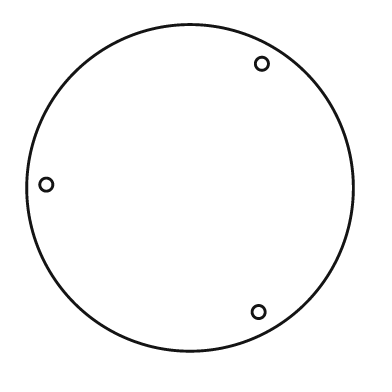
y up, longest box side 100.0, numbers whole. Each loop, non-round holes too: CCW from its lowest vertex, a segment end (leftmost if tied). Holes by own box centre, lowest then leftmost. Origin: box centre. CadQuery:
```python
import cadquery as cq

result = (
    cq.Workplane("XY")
    .moveTo(0.0, 0.0)
    .circle(50.0)
    .moveTo(21.0, -38.0)
    .circle(2.0)
    .moveTo(-44.0, 1.0)
    .circle(2.0)
    .moveTo(22.0, 38.0)
    .circle(2.0)
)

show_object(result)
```